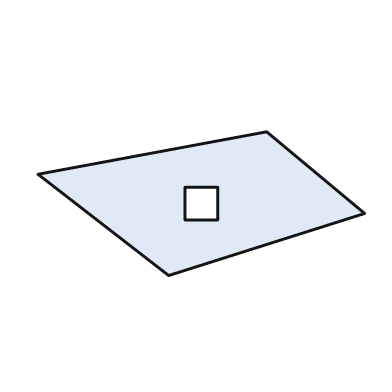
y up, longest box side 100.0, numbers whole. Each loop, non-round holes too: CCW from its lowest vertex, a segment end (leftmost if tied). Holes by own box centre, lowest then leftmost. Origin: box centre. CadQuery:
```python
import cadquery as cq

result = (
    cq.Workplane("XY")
    .moveTo(-10.0, -22.0)
    .lineTo(50.0, -3.0)
    .lineTo(20.0, 22.0)
    .lineTo(-50.0, 9.0)
    .close()
    .moveTo(-5.0, -5.0)
    .lineTo(5.0, -5.0)
    .lineTo(5.0, 5.0)
    .lineTo(-5.0, 5.0)
    .close()
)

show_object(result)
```